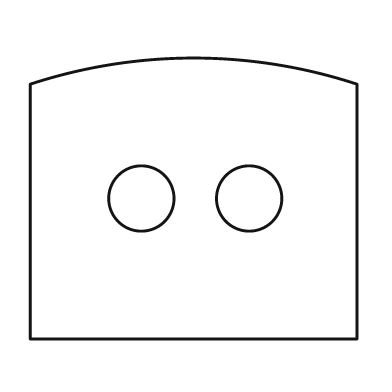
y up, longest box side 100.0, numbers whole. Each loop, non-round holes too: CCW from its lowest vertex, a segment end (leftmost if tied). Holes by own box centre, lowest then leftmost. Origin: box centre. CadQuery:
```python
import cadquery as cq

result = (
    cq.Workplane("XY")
    .moveTo(-50.0, -43.0)
    .lineTo(50.0, -43.0)
    .lineTo(50.0, 35.0)
    .threePointArc((0.0, 43.0), (-50.0, 35.0))
    .close()
    .moveTo(-16.0, 0.0)
    .circle(10.0)
    .moveTo(17.0, 0.0)
    .circle(10.0)
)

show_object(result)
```